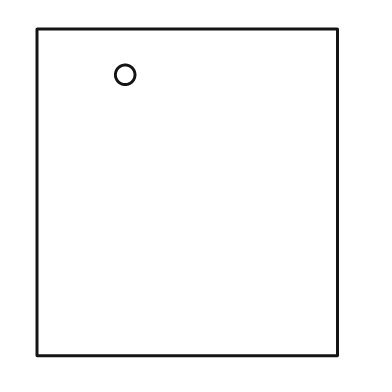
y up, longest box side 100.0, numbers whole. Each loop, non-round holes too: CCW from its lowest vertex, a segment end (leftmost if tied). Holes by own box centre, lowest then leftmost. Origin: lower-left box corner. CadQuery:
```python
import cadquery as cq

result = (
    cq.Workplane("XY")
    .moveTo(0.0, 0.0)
    .lineTo(92.0, 0.0)
    .lineTo(92.0, 100.0)
    .lineTo(0.0, 100.0)
    .close()
    .moveTo(27.0, 86.0)
    .circle(3.0)
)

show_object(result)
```